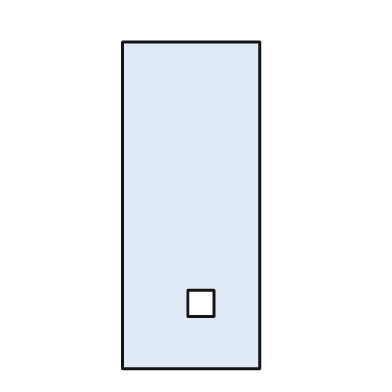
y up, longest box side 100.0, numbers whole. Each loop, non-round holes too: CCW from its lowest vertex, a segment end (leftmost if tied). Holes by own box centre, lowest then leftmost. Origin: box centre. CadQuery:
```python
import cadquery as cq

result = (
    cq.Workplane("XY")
    .moveTo(-21.0, -50.0)
    .lineTo(21.0, -50.0)
    .lineTo(21.0, 50.0)
    .lineTo(-21.0, 50.0)
    .close()
    .moveTo(-1.0, -34.0)
    .lineTo(7.0, -34.0)
    .lineTo(7.0, -26.0)
    .lineTo(-1.0, -26.0)
    .close()
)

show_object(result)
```